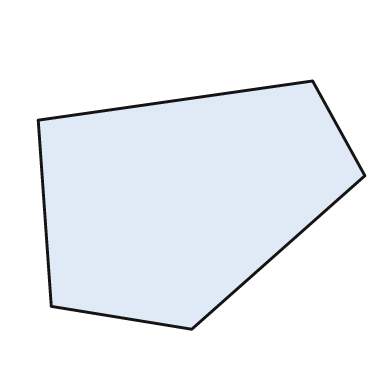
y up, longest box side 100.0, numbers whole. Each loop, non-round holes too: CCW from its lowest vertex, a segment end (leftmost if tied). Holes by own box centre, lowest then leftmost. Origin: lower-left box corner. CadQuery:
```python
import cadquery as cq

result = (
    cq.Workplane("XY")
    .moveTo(47.0, 0.0)
    .lineTo(100.0, 47.0)
    .lineTo(84.0, 76.0)
    .lineTo(0.0, 64.0)
    .lineTo(4.0, 7.0)
    .close()
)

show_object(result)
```